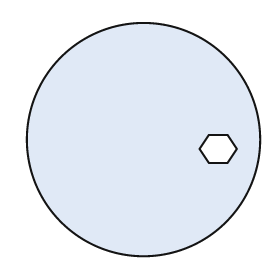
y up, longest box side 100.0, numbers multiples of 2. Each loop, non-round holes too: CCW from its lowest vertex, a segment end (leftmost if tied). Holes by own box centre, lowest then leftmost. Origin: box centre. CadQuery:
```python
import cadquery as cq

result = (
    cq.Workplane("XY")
    .moveTo(0.0, 0.0)
    .circle(50.0)
    .moveTo(28.0, -10.0)
    .lineTo(36.0, -10.0)
    .lineTo(40.0, -4.0)
    .lineTo(36.0, 2.0)
    .lineTo(28.0, 2.0)
    .lineTo(24.0, -4.0)
    .close()
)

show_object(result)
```